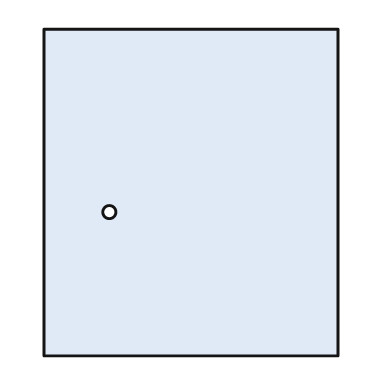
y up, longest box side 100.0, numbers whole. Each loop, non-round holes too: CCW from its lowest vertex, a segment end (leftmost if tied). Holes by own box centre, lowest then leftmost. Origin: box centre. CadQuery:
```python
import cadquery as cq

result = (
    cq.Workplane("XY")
    .moveTo(-45.0, -50.0)
    .lineTo(45.0, -50.0)
    .lineTo(45.0, 50.0)
    .lineTo(-45.0, 50.0)
    .close()
    .moveTo(-25.0, -6.0)
    .circle(2.0)
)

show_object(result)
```